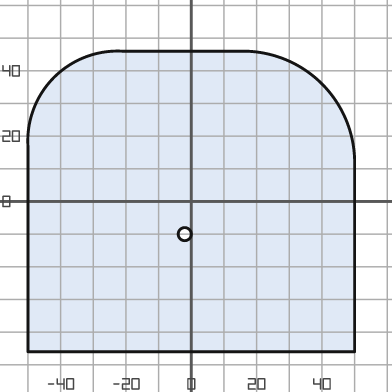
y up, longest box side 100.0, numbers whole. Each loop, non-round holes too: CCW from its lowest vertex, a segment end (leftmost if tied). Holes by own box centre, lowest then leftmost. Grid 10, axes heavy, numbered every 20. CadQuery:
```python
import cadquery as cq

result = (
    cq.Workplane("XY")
    .moveTo(-50.0, -46.0)
    .lineTo(50.0, -46.0)
    .lineTo(50.0, 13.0)
    .threePointArc((40.0, 36.0), (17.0, 46.0))
    .lineTo(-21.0, 46.0)
    .threePointArc((-42.0, 38.0), (-50.0, 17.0))
    .close()
    .moveTo(-2.0, -10.0)
    .circle(2.0)
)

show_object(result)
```